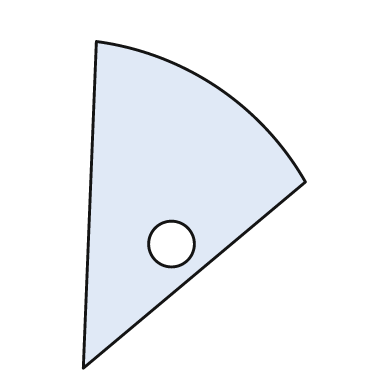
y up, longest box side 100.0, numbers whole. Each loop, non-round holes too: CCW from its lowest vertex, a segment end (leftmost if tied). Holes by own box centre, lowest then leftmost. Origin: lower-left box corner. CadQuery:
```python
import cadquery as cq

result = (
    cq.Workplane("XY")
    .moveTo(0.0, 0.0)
    .lineTo(68.0, 57.0)
    .threePointArc((41.0, 86.0), (4.0, 100.0))
    .close()
    .moveTo(27.0, 38.0)
    .circle(7.0)
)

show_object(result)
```